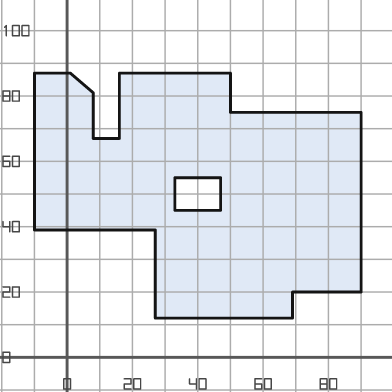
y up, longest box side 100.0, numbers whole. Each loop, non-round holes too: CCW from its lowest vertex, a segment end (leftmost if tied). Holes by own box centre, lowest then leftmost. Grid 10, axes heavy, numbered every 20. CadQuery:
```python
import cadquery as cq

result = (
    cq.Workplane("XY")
    .moveTo(27.0, 12.0)
    .lineTo(69.0, 12.0)
    .lineTo(69.0, 20.0)
    .lineTo(90.0, 20.0)
    .lineTo(90.0, 75.0)
    .lineTo(50.0, 75.0)
    .lineTo(50.0, 87.0)
    .lineTo(16.0, 87.0)
    .lineTo(16.0, 67.0)
    .lineTo(8.0, 67.0)
    .lineTo(8.0, 81.0)
    .lineTo(1.0, 87.0)
    .lineTo(-10.0, 87.0)
    .lineTo(-10.0, 39.0)
    .lineTo(27.0, 39.0)
    .close()
    .moveTo(33.0, 45.0)
    .lineTo(47.0, 45.0)
    .lineTo(47.0, 55.0)
    .lineTo(33.0, 55.0)
    .close()
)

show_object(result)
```